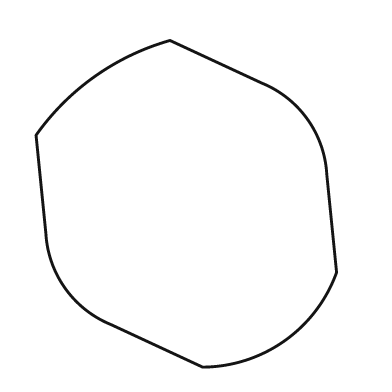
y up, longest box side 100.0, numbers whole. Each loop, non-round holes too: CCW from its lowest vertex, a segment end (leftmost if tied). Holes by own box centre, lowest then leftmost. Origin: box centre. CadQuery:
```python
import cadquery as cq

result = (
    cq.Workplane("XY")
    .moveTo(5.0, -50.0)
    .threePointArc((30.0, -42.0), (46.0, -21.0))
    .lineTo(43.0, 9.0)
    .threePointArc((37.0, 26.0), (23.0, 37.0))
    .lineTo(-5.0, 50.0)
    .threePointArc((-28.0, 39.0), (-46.0, 21.0))
    .lineTo(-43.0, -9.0)
    .threePointArc((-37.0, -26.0), (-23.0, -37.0))
    .close()
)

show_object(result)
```